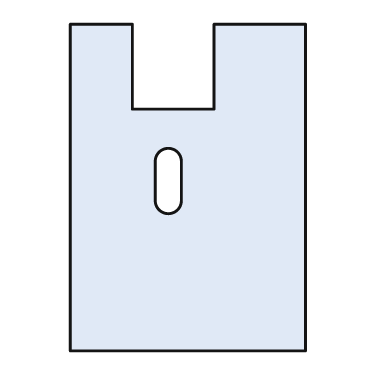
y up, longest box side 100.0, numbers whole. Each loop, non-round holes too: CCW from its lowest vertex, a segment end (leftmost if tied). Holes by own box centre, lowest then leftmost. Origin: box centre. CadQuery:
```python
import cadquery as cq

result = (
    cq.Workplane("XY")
    .moveTo(-36.0, -50.0)
    .lineTo(36.0, -50.0)
    .lineTo(36.0, 50.0)
    .lineTo(8.0, 50.0)
    .lineTo(8.0, 24.0)
    .lineTo(-17.0, 24.0)
    .lineTo(-17.0, 50.0)
    .lineTo(-36.0, 50.0)
    .close()
    .moveTo(-10.0, -4.0)
    .threePointArc((-6.0, -8.0), (-2.0, -4.0))
    .lineTo(-2.0, 8.0)
    .threePointArc((-6.0, 12.0), (-10.0, 8.0))
    .close()
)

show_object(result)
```